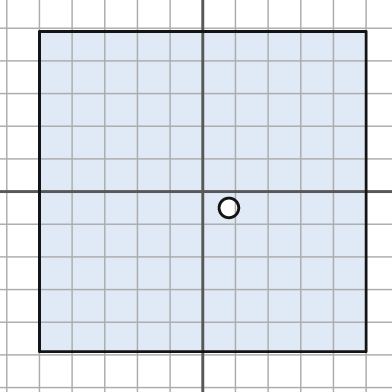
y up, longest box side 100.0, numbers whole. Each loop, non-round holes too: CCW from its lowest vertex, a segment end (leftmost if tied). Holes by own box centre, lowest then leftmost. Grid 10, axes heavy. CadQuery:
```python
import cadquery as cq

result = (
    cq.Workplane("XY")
    .moveTo(-50.0, -49.0)
    .lineTo(50.0, -49.0)
    .lineTo(50.0, 49.0)
    .lineTo(-50.0, 49.0)
    .close()
    .moveTo(8.0, -5.0)
    .circle(3.0)
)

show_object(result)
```